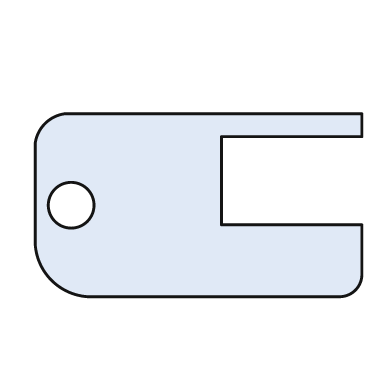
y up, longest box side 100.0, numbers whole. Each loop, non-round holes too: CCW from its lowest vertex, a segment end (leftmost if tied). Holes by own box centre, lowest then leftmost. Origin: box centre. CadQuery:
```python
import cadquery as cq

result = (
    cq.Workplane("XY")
    .moveTo(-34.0, -28.0)
    .lineTo(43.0, -28.0)
    .threePointArc((48.0, -26.0), (50.0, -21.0))
    .lineTo(50.0, -6.0)
    .lineTo(7.0, -6.0)
    .lineTo(7.0, 21.0)
    .lineTo(50.0, 21.0)
    .lineTo(50.0, 28.0)
    .lineTo(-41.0, 28.0)
    .threePointArc((-47.0, 25.0), (-50.0, 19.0))
    .lineTo(-50.0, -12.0)
    .threePointArc((-45.0, -23.0), (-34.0, -28.0))
    .close()
    .moveTo(-39.0, 0.0)
    .circle(7.0)
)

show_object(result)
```